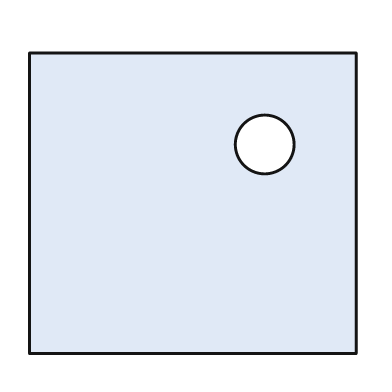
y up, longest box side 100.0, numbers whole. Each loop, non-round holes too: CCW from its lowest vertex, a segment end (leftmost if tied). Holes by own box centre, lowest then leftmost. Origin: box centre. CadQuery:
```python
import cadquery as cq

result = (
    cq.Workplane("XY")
    .moveTo(-50.0, -46.0)
    .lineTo(50.0, -46.0)
    .lineTo(50.0, 46.0)
    .lineTo(-50.0, 46.0)
    .close()
    .moveTo(22.0, 18.0)
    .circle(9.0)
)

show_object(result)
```